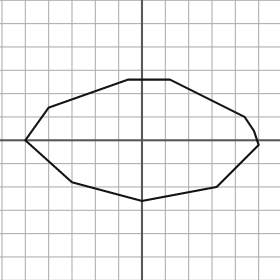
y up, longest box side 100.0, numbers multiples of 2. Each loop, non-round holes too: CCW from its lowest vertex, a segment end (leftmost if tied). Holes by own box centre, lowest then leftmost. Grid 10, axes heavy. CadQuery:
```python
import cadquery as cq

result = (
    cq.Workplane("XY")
    .moveTo(0.0, -26.0)
    .lineTo(32.0, -20.0)
    .lineTo(50.0, -2.0)
    .lineTo(48.0, 4.0)
    .lineTo(44.0, 10.0)
    .lineTo(12.0, 26.0)
    .lineTo(-6.0, 26.0)
    .lineTo(-40.0, 14.0)
    .lineTo(-50.0, 0.0)
    .lineTo(-30.0, -18.0)
    .close()
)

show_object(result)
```